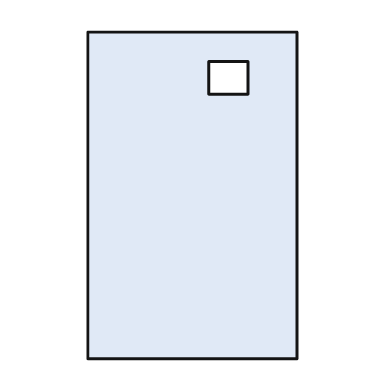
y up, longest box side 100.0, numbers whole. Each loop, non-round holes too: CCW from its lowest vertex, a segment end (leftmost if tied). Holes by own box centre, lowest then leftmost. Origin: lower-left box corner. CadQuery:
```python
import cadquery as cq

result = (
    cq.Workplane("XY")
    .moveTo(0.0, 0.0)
    .lineTo(64.0, 0.0)
    .lineTo(64.0, 100.0)
    .lineTo(0.0, 100.0)
    .close()
    .moveTo(37.0, 81.0)
    .lineTo(49.0, 81.0)
    .lineTo(49.0, 91.0)
    .lineTo(37.0, 91.0)
    .close()
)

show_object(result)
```